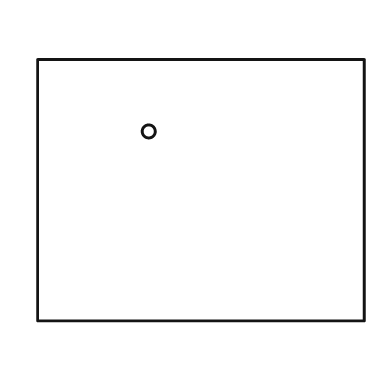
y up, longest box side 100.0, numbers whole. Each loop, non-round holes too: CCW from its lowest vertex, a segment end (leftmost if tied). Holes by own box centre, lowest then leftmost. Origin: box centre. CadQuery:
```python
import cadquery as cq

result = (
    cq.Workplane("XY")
    .moveTo(-50.0, -40.0)
    .lineTo(50.0, -40.0)
    .lineTo(50.0, 40.0)
    .lineTo(-50.0, 40.0)
    .close()
    .moveTo(-16.0, 18.0)
    .circle(2.0)
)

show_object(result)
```